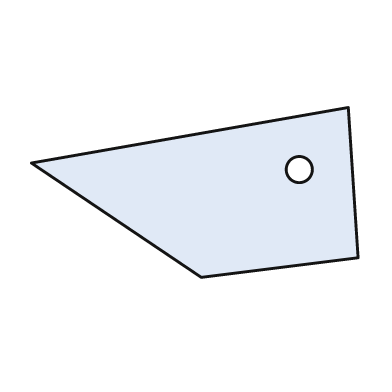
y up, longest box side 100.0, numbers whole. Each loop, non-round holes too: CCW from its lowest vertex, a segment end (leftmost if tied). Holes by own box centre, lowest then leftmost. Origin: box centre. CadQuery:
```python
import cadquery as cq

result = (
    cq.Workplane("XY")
    .moveTo(2.0, -26.0)
    .lineTo(50.0, -20.0)
    .lineTo(47.0, 26.0)
    .lineTo(-50.0, 9.0)
    .close()
    .moveTo(32.0, 7.0)
    .circle(4.0)
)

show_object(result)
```